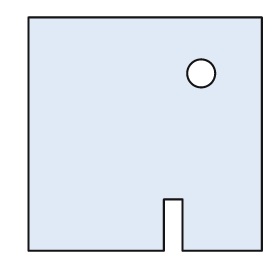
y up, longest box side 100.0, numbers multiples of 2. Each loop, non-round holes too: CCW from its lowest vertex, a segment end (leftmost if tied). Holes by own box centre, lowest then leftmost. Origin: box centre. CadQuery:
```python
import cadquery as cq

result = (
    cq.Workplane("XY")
    .moveTo(-50.0, -50.0)
    .lineTo(8.0, -50.0)
    .lineTo(8.0, -28.0)
    .lineTo(16.0, -28.0)
    .lineTo(16.0, -50.0)
    .lineTo(50.0, -50.0)
    .lineTo(50.0, 50.0)
    .lineTo(-50.0, 50.0)
    .close()
    .moveTo(24.0, 26.0)
    .circle(6.0)
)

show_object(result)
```